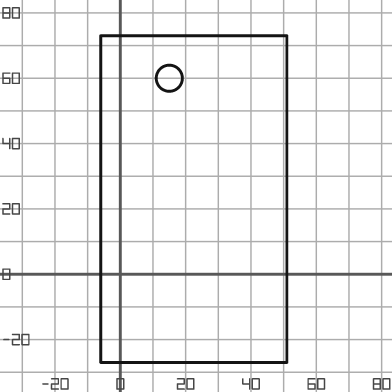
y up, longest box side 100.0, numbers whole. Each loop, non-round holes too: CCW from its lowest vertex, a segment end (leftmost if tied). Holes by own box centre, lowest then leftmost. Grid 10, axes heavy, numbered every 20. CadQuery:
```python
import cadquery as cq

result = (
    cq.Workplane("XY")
    .moveTo(-6.0, -27.0)
    .lineTo(51.0, -27.0)
    .lineTo(51.0, 73.0)
    .lineTo(-6.0, 73.0)
    .close()
    .moveTo(15.0, 60.0)
    .circle(4.0)
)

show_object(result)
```